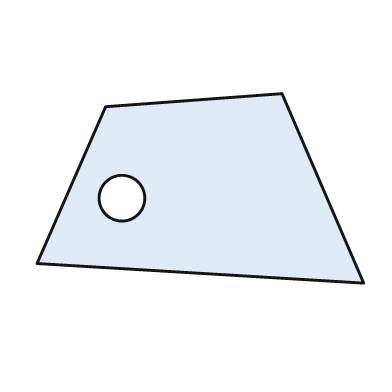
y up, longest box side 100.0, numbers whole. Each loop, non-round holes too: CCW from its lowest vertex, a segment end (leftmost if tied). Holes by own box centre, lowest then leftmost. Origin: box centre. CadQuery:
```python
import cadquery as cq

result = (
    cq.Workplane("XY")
    .moveTo(50.0, -29.0)
    .lineTo(25.0, 29.0)
    .lineTo(-29.0, 25.0)
    .lineTo(-50.0, -23.0)
    .close()
    .moveTo(-24.0, -3.0)
    .circle(7.0)
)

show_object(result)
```